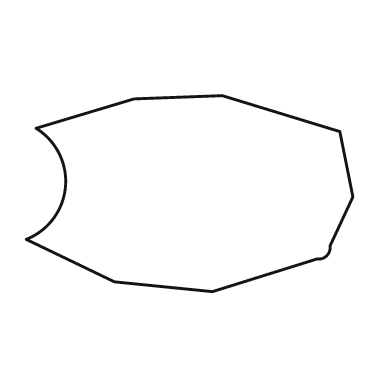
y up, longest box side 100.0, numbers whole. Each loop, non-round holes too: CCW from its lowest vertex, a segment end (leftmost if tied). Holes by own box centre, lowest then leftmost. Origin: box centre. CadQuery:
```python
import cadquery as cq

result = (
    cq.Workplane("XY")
    .moveTo(7.0, -30.0)
    .lineTo(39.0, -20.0)
    .threePointArc((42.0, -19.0), (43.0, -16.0))
    .lineTo(50.0, -1.0)
    .lineTo(46.0, 19.0)
    .lineTo(10.0, 30.0)
    .lineTo(-17.0, 29.0)
    .lineTo(-47.0, 20.0)
    .threePointArc((-38.0, 2.0), (-50.0, -14.0))
    .lineTo(-23.0, -27.0)
    .close()
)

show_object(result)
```